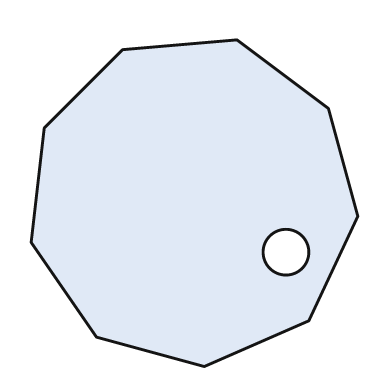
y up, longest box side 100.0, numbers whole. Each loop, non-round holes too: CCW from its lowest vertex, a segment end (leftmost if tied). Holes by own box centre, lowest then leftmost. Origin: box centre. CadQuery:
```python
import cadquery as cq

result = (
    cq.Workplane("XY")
    .moveTo(3.0, -50.0)
    .lineTo(35.0, -36.0)
    .lineTo(50.0, -4.0)
    .lineTo(41.0, 29.0)
    .lineTo(13.0, 50.0)
    .lineTo(-22.0, 47.0)
    .lineTo(-46.0, 23.0)
    .lineTo(-50.0, -12.0)
    .lineTo(-30.0, -41.0)
    .close()
    .moveTo(28.0, -15.0)
    .circle(7.0)
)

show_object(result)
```